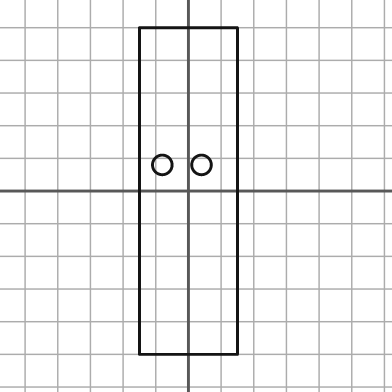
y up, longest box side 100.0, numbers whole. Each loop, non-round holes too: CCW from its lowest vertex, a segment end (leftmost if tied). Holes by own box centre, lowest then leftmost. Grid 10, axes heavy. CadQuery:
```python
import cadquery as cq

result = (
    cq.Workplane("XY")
    .moveTo(-15.0, -50.0)
    .lineTo(15.0, -50.0)
    .lineTo(15.0, 50.0)
    .lineTo(-15.0, 50.0)
    .close()
    .moveTo(-8.0, 8.0)
    .circle(3.0)
    .moveTo(4.0, 8.0)
    .circle(3.0)
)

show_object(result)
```